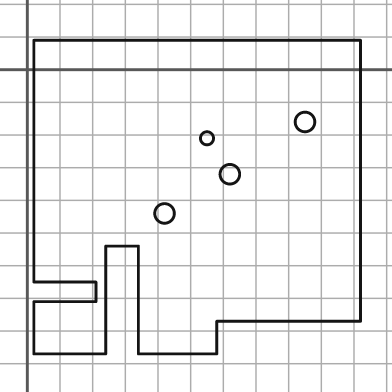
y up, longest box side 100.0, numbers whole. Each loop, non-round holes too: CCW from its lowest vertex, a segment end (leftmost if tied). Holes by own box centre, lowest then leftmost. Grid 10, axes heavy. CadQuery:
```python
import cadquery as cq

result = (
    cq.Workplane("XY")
    .moveTo(2.0, -87.0)
    .lineTo(24.0, -87.0)
    .lineTo(24.0, -54.0)
    .lineTo(34.0, -54.0)
    .lineTo(34.0, -87.0)
    .lineTo(58.0, -87.0)
    .lineTo(58.0, -77.0)
    .lineTo(102.0, -77.0)
    .lineTo(102.0, 9.0)
    .lineTo(2.0, 9.0)
    .lineTo(2.0, -65.0)
    .lineTo(21.0, -65.0)
    .lineTo(21.0, -71.0)
    .lineTo(2.0, -71.0)
    .close()
    .moveTo(42.0, -44.0)
    .circle(3.0)
    .moveTo(62.0, -32.0)
    .circle(3.0)
    .moveTo(55.0, -21.0)
    .circle(2.0)
    .moveTo(85.0, -16.0)
    .circle(3.0)
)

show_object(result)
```